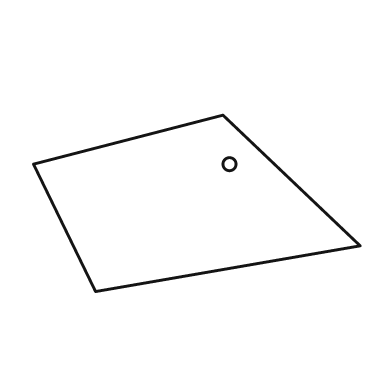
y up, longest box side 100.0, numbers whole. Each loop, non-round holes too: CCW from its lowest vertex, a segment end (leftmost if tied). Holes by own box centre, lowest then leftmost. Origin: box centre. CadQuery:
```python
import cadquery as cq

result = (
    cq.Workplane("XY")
    .moveTo(-31.0, -27.0)
    .lineTo(50.0, -13.0)
    .lineTo(8.0, 27.0)
    .lineTo(-50.0, 12.0)
    .close()
    .moveTo(10.0, 12.0)
    .circle(2.0)
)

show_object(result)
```